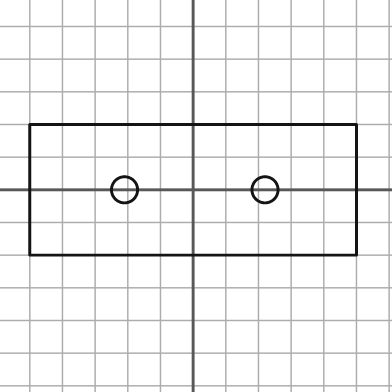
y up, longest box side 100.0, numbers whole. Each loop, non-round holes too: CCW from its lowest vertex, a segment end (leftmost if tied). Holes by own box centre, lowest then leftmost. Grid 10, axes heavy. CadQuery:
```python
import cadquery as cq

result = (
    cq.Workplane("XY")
    .moveTo(-50.0, -20.0)
    .lineTo(50.0, -20.0)
    .lineTo(50.0, 20.0)
    .lineTo(-50.0, 20.0)
    .close()
    .moveTo(-21.0, 0.0)
    .circle(4.0)
    .moveTo(22.0, 0.0)
    .circle(4.0)
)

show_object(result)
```